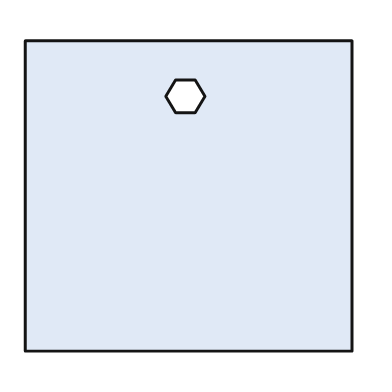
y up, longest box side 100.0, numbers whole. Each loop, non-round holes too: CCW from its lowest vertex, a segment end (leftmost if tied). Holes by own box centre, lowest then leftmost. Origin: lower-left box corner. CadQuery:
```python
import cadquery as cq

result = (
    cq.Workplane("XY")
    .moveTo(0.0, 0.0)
    .lineTo(100.0, 0.0)
    .lineTo(100.0, 95.0)
    .lineTo(0.0, 95.0)
    .close()
    .moveTo(46.0, 73.0)
    .lineTo(52.0, 73.0)
    .lineTo(55.0, 78.0)
    .lineTo(52.0, 83.0)
    .lineTo(46.0, 83.0)
    .lineTo(43.0, 78.0)
    .close()
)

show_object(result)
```